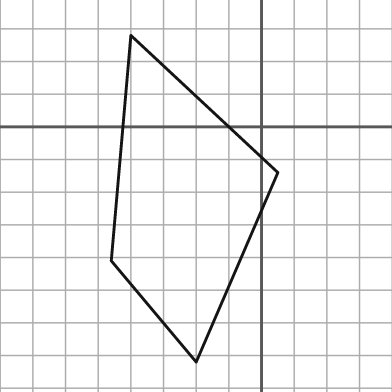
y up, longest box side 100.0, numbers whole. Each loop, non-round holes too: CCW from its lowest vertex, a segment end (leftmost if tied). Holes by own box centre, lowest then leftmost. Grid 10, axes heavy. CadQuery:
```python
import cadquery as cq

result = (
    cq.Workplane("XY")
    .moveTo(-20.0, -72.0)
    .lineTo(5.0, -14.0)
    .lineTo(-40.0, 28.0)
    .lineTo(-46.0, -41.0)
    .close()
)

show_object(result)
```